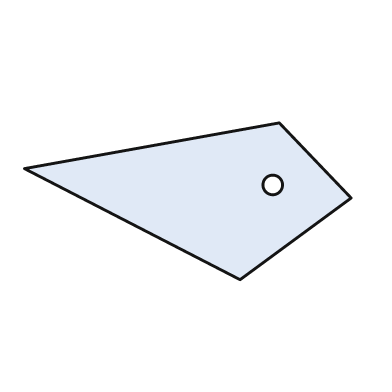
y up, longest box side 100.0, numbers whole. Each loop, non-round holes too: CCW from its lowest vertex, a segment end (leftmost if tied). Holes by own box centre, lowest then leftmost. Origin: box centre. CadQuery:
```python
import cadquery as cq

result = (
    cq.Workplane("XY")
    .moveTo(16.0, -24.0)
    .lineTo(50.0, 1.0)
    .lineTo(28.0, 24.0)
    .lineTo(-50.0, 10.0)
    .close()
    .moveTo(26.0, 5.0)
    .circle(3.0)
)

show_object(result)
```